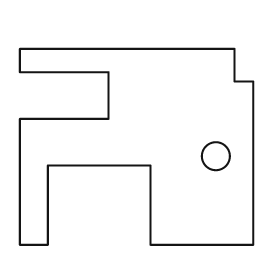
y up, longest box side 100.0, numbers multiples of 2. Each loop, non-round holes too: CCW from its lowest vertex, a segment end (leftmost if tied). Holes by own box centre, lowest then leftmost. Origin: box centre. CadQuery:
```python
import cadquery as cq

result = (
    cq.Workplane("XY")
    .moveTo(-50.0, -42.0)
    .lineTo(-38.0, -42.0)
    .lineTo(-38.0, -8.0)
    .lineTo(6.0, -8.0)
    .lineTo(6.0, -42.0)
    .lineTo(50.0, -42.0)
    .lineTo(50.0, 28.0)
    .lineTo(42.0, 28.0)
    .lineTo(42.0, 42.0)
    .lineTo(-50.0, 42.0)
    .lineTo(-50.0, 32.0)
    .lineTo(-12.0, 32.0)
    .lineTo(-12.0, 12.0)
    .lineTo(-50.0, 12.0)
    .close()
    .moveTo(34.0, -4.0)
    .circle(6.0)
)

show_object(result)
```